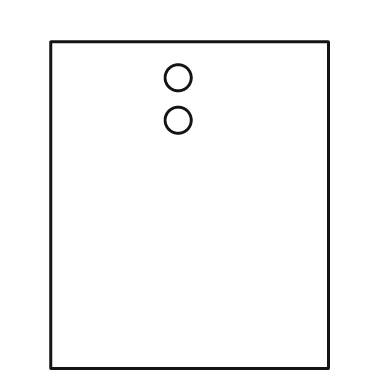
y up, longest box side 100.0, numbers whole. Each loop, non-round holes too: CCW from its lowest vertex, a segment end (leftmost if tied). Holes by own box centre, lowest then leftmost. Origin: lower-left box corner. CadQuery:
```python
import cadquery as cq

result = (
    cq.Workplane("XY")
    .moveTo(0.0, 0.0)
    .lineTo(85.0, 0.0)
    .lineTo(85.0, 100.0)
    .lineTo(0.0, 100.0)
    .close()
    .moveTo(39.0, 76.0)
    .circle(4.0)
    .moveTo(39.0, 89.0)
    .circle(4.0)
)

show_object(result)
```